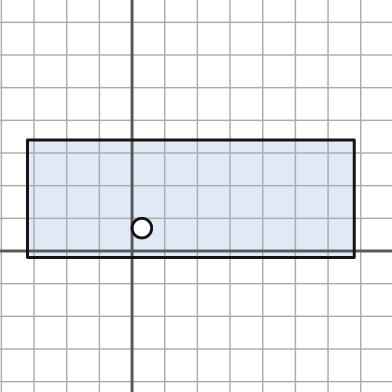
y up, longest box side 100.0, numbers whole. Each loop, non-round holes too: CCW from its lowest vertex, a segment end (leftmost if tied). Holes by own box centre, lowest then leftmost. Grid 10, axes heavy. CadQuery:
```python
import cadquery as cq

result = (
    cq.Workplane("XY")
    .moveTo(-32.0, -2.0)
    .lineTo(68.0, -2.0)
    .lineTo(68.0, 34.0)
    .lineTo(-32.0, 34.0)
    .close()
    .moveTo(3.0, 7.0)
    .circle(3.0)
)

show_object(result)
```